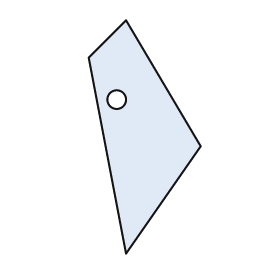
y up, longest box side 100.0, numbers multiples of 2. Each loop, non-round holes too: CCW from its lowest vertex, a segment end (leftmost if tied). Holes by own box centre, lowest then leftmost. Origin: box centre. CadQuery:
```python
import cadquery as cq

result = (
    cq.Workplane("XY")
    .moveTo(-8.0, -50.0)
    .lineTo(24.0, -4.0)
    .lineTo(-8.0, 50.0)
    .lineTo(-24.0, 34.0)
    .close()
    .moveTo(-12.0, 16.0)
    .circle(4.0)
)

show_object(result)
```